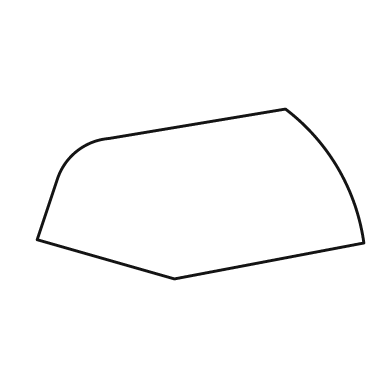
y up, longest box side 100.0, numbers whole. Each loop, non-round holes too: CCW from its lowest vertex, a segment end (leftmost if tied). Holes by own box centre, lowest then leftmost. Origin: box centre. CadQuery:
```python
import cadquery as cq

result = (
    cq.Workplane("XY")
    .moveTo(-8.0, -26.0)
    .lineTo(50.0, -15.0)
    .threePointArc((42.0, 8.0), (26.0, 26.0))
    .lineTo(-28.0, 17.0)
    .threePointArc((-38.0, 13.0), (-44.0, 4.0))
    .lineTo(-50.0, -14.0)
    .close()
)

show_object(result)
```